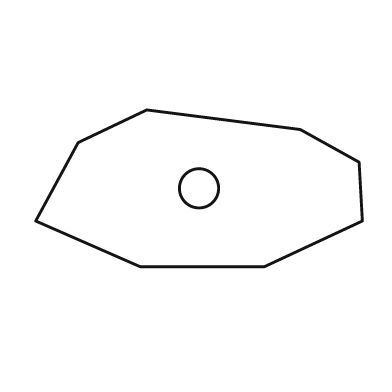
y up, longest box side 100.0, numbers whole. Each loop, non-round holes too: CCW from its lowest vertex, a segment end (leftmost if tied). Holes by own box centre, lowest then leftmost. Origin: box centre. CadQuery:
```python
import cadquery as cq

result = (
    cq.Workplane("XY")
    .moveTo(-18.0, -24.0)
    .lineTo(20.0, -24.0)
    .lineTo(50.0, -10.0)
    .lineTo(49.0, 8.0)
    .lineTo(31.0, 18.0)
    .lineTo(-16.0, 24.0)
    .lineTo(-37.0, 14.0)
    .lineTo(-50.0, -10.0)
    .close()
    .moveTo(0.0, 0.0)
    .circle(6.0)
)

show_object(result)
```